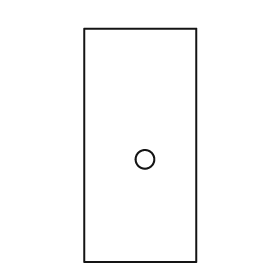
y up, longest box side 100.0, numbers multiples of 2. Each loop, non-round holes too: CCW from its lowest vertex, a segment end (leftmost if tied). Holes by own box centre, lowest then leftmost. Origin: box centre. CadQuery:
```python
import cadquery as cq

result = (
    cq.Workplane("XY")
    .moveTo(-24.0, -50.0)
    .lineTo(24.0, -50.0)
    .lineTo(24.0, 50.0)
    .lineTo(-24.0, 50.0)
    .close()
    .moveTo(2.0, -6.0)
    .circle(4.0)
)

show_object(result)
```